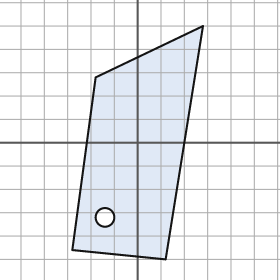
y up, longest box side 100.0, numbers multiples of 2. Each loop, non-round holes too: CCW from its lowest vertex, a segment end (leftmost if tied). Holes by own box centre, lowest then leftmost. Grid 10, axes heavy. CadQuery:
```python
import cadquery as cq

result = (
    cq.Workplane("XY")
    .moveTo(12.0, -50.0)
    .lineTo(28.0, 50.0)
    .lineTo(-18.0, 28.0)
    .lineTo(-28.0, -46.0)
    .close()
    .moveTo(-14.0, -32.0)
    .circle(4.0)
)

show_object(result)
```